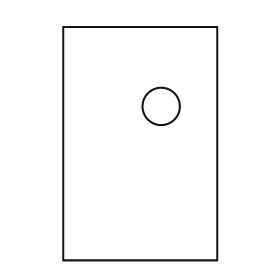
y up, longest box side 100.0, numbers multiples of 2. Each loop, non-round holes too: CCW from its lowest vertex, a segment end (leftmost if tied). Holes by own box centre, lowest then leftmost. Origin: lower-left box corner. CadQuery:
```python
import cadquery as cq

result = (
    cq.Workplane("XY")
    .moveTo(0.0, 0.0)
    .lineTo(66.0, 0.0)
    .lineTo(66.0, 100.0)
    .lineTo(0.0, 100.0)
    .close()
    .moveTo(42.0, 66.0)
    .circle(8.0)
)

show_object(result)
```